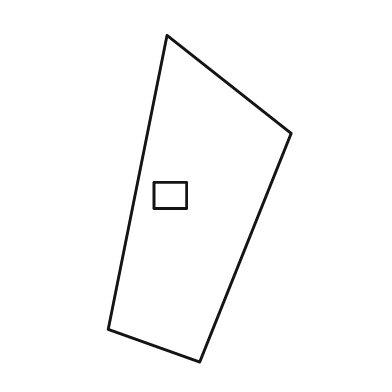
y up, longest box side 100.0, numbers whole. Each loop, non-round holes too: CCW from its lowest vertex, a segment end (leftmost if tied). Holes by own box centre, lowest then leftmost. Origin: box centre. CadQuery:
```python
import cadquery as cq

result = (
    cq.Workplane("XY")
    .moveTo(0.0, -50.0)
    .lineTo(28.0, 20.0)
    .lineTo(-10.0, 50.0)
    .lineTo(-28.0, -40.0)
    .close()
    .moveTo(-14.0, -3.0)
    .lineTo(-4.0, -3.0)
    .lineTo(-4.0, 5.0)
    .lineTo(-14.0, 5.0)
    .close()
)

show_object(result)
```